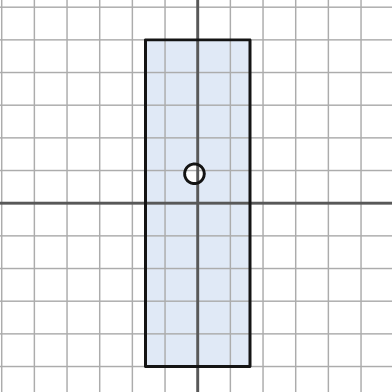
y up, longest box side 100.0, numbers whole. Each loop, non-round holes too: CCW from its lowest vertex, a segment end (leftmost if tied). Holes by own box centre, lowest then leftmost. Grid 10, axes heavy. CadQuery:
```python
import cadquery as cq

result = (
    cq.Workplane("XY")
    .moveTo(-16.0, -50.0)
    .lineTo(16.0, -50.0)
    .lineTo(16.0, 50.0)
    .lineTo(-16.0, 50.0)
    .close()
    .moveTo(-1.0, 9.0)
    .circle(3.0)
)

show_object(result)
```